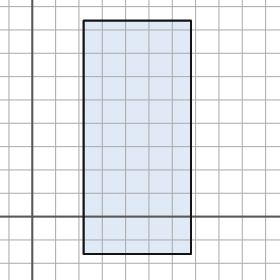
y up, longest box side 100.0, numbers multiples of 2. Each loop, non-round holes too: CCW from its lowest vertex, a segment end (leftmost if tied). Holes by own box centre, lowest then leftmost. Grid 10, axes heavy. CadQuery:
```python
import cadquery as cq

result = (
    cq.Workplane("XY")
    .moveTo(22.0, -16.0)
    .lineTo(68.0, -16.0)
    .lineTo(68.0, 84.0)
    .lineTo(22.0, 84.0)
    .close()
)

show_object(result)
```